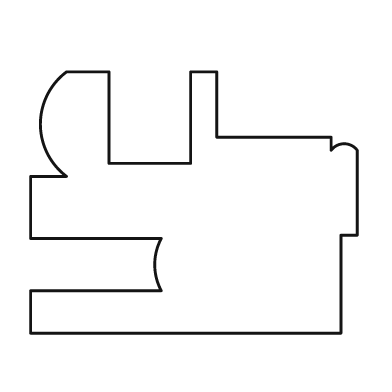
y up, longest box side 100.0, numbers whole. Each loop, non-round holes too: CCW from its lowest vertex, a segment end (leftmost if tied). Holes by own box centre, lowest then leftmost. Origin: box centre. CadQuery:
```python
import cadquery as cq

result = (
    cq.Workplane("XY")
    .moveTo(-50.0, -40.0)
    .lineTo(45.0, -40.0)
    .lineTo(45.0, -10.0)
    .lineTo(50.0, -10.0)
    .lineTo(50.0, 16.0)
    .threePointArc((46.0, 18.0), (42.0, 16.0))
    .lineTo(42.0, 20.0)
    .lineTo(7.0, 20.0)
    .lineTo(7.0, 40.0)
    .lineTo(-1.0, 40.0)
    .lineTo(-1.0, 12.0)
    .lineTo(-26.0, 12.0)
    .lineTo(-26.0, 40.0)
    .lineTo(-39.0, 40.0)
    .threePointArc((-47.0, 24.0), (-39.0, 8.0))
    .lineTo(-50.0, 8.0)
    .lineTo(-50.0, -11.0)
    .lineTo(-10.0, -11.0)
    .threePointArc((-12.0, -19.0), (-10.0, -27.0))
    .lineTo(-50.0, -27.0)
    .close()
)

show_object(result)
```